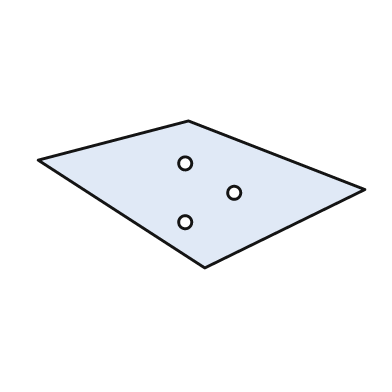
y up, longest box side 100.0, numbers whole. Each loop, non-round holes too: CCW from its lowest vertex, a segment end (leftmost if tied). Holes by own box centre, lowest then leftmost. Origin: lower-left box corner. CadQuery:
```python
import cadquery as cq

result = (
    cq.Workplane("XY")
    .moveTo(51.0, 0.0)
    .lineTo(100.0, 24.0)
    .lineTo(46.0, 45.0)
    .lineTo(0.0, 33.0)
    .close()
    .moveTo(45.0, 14.0)
    .circle(2.0)
    .moveTo(60.0, 23.0)
    .circle(2.0)
    .moveTo(45.0, 32.0)
    .circle(2.0)
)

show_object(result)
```